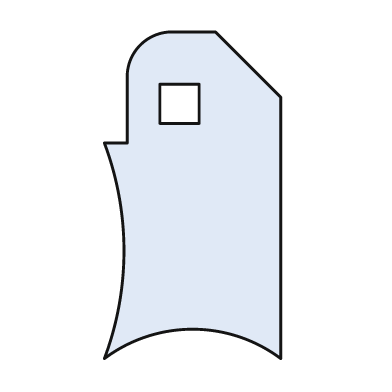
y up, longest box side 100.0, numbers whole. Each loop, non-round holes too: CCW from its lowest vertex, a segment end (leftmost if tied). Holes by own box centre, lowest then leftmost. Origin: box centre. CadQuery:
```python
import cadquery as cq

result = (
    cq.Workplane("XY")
    .moveTo(-27.0, -50.0)
    .threePointArc((0.0, -41.0), (27.0, -50.0))
    .lineTo(27.0, 30.0)
    .lineTo(7.0, 50.0)
    .lineTo(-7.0, 50.0)
    .threePointArc((-16.0, 46.0), (-20.0, 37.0))
    .lineTo(-20.0, 16.0)
    .lineTo(-27.0, 16.0)
    .threePointArc((-21.0, -17.0), (-27.0, -50.0))
    .close()
    .moveTo(-10.0, 22.0)
    .lineTo(2.0, 22.0)
    .lineTo(2.0, 34.0)
    .lineTo(-10.0, 34.0)
    .close()
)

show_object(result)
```